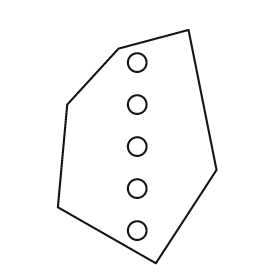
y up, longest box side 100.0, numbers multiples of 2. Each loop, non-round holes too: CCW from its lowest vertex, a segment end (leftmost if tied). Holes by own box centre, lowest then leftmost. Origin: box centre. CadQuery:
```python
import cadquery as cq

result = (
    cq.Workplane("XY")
    .moveTo(8.0, -50.0)
    .lineTo(34.0, -10.0)
    .lineTo(22.0, 50.0)
    .lineTo(-8.0, 42.0)
    .lineTo(-30.0, 18.0)
    .lineTo(-34.0, -26.0)
    .close()
    .moveTo(0.0, -36.0)
    .circle(4.0)
    .moveTo(0.0, -18.0)
    .circle(4.0)
    .moveTo(0.0, 0.0)
    .circle(4.0)
    .moveTo(0.0, 18.0)
    .circle(4.0)
    .moveTo(0.0, 36.0)
    .circle(4.0)
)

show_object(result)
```